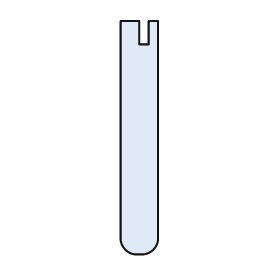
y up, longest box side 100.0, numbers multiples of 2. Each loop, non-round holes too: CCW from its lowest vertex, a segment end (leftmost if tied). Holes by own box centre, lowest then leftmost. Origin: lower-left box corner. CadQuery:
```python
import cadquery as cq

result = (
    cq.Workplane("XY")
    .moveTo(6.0, 0.0)
    .lineTo(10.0, 0.0)
    .threePointArc((14.0, 2.0), (16.0, 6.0))
    .lineTo(16.0, 100.0)
    .lineTo(12.0, 100.0)
    .lineTo(12.0, 90.0)
    .lineTo(8.0, 90.0)
    .lineTo(8.0, 100.0)
    .lineTo(0.0, 100.0)
    .lineTo(0.0, 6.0)
    .threePointArc((2.0, 2.0), (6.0, 0.0))
    .close()
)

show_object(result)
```